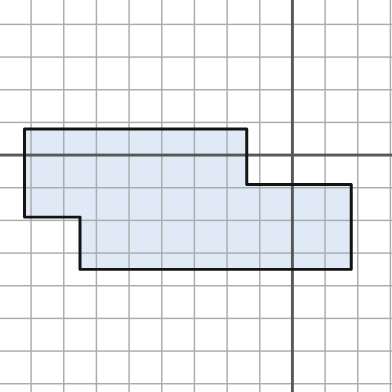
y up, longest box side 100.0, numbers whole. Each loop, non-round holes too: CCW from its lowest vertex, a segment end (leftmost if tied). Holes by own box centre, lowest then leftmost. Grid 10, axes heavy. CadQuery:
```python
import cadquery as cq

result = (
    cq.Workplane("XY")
    .moveTo(-65.0, -35.0)
    .lineTo(18.0, -35.0)
    .lineTo(18.0, -9.0)
    .lineTo(-14.0, -9.0)
    .lineTo(-14.0, 8.0)
    .lineTo(-82.0, 8.0)
    .lineTo(-82.0, -19.0)
    .lineTo(-65.0, -19.0)
    .close()
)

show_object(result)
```